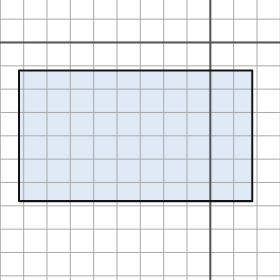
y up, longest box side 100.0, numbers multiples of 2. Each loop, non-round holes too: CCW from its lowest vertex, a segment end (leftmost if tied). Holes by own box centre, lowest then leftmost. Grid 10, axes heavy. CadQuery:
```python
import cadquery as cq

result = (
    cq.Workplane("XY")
    .moveTo(-82.0, -68.0)
    .lineTo(18.0, -68.0)
    .lineTo(18.0, -12.0)
    .lineTo(-82.0, -12.0)
    .close()
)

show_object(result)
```